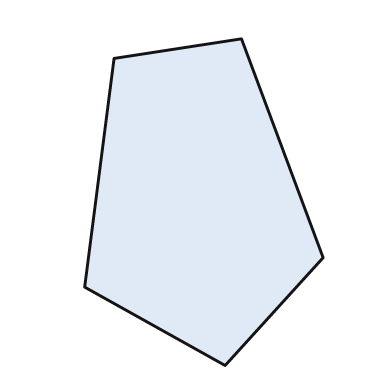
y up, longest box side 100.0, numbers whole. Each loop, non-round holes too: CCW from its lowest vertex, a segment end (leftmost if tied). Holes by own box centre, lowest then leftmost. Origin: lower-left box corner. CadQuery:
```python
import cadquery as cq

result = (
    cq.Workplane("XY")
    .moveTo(43.0, 0.0)
    .lineTo(73.0, 33.0)
    .lineTo(48.0, 100.0)
    .lineTo(9.0, 94.0)
    .lineTo(0.0, 24.0)
    .close()
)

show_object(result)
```